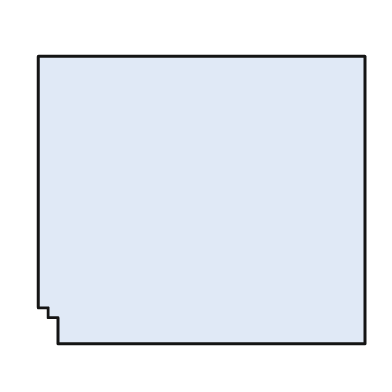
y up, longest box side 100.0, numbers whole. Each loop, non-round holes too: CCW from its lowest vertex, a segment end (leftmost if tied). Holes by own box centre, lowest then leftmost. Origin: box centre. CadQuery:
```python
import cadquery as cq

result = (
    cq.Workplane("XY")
    .moveTo(-44.0, -44.0)
    .lineTo(50.0, -44.0)
    .lineTo(50.0, 44.0)
    .lineTo(-50.0, 44.0)
    .lineTo(-50.0, -33.0)
    .lineTo(-47.0, -33.0)
    .lineTo(-47.0, -36.0)
    .lineTo(-44.0, -36.0)
    .close()
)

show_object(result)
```